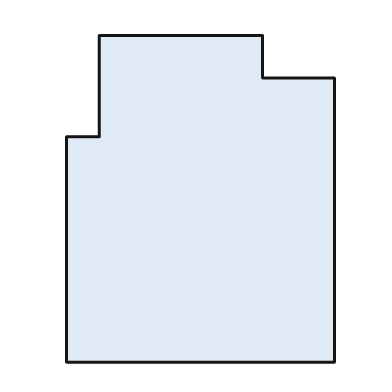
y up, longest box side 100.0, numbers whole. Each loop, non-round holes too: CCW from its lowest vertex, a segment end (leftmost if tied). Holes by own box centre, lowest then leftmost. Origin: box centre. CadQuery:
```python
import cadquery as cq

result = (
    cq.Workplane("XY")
    .moveTo(-41.0, -50.0)
    .lineTo(41.0, -50.0)
    .lineTo(41.0, 37.0)
    .lineTo(19.0, 37.0)
    .lineTo(19.0, 50.0)
    .lineTo(-31.0, 50.0)
    .lineTo(-31.0, 19.0)
    .lineTo(-41.0, 19.0)
    .close()
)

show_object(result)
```